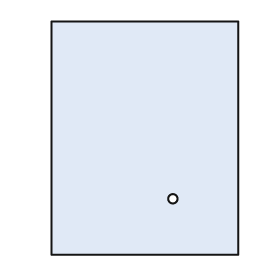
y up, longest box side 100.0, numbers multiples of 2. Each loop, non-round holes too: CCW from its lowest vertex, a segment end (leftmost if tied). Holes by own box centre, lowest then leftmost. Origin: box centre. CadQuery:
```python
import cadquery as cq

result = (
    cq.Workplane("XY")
    .moveTo(-40.0, -50.0)
    .lineTo(40.0, -50.0)
    .lineTo(40.0, 50.0)
    .lineTo(-40.0, 50.0)
    .close()
    .moveTo(12.0, -26.0)
    .circle(2.0)
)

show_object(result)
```